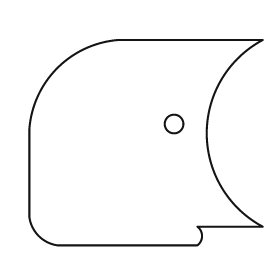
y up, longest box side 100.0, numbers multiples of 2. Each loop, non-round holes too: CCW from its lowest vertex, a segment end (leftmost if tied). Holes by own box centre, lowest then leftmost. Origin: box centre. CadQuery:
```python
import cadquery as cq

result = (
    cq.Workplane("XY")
    .moveTo(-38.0, -44.0)
    .lineTo(22.0, -44.0)
    .threePointArc((24.0, -40.0), (22.0, -36.0))
    .lineTo(50.0, -36.0)
    .threePointArc((26.0, 4.0), (50.0, 44.0))
    .lineTo(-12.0, 44.0)
    .threePointArc((-38.0, 32.0), (-50.0, 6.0))
    .lineTo(-50.0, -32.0)
    .threePointArc((-46.0, -40.0), (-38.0, -44.0))
    .close()
    .moveTo(12.0, 8.0)
    .circle(4.0)
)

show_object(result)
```